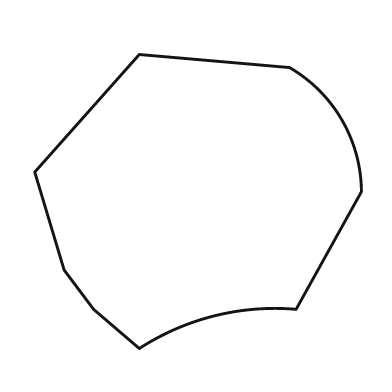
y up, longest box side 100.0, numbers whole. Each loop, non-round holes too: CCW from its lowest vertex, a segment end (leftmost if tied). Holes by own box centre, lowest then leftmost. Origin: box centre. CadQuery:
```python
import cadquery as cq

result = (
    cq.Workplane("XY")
    .moveTo(-18.0, -45.0)
    .threePointArc((5.0, -35.0), (30.0, -33.0))
    .lineTo(50.0, 3.0)
    .threePointArc((44.0, 25.0), (28.0, 41.0))
    .lineTo(-18.0, 45.0)
    .lineTo(-50.0, 9.0)
    .lineTo(-41.0, -21.0)
    .lineTo(-32.0, -33.0)
    .close()
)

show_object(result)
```